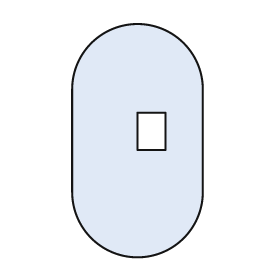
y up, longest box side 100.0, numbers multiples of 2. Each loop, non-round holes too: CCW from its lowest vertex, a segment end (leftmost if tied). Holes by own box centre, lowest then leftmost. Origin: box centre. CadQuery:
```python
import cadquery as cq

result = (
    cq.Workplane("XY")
    .moveTo(-28.0, -22.0)
    .threePointArc((0.0, -50.0), (28.0, -22.0))
    .lineTo(28.0, 22.0)
    .threePointArc((0.0, 50.0), (-28.0, 22.0))
    .close()
    .moveTo(0.0, -4.0)
    .lineTo(12.0, -4.0)
    .lineTo(12.0, 12.0)
    .lineTo(0.0, 12.0)
    .close()
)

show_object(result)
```